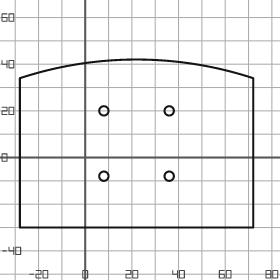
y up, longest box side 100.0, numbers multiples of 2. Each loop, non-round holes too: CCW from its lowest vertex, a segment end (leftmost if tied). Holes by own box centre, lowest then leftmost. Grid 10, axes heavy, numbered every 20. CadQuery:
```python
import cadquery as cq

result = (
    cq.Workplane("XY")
    .moveTo(-28.0, -30.0)
    .lineTo(72.0, -30.0)
    .lineTo(72.0, 34.0)
    .threePointArc((22.0, 42.0), (-28.0, 34.0))
    .close()
    .moveTo(8.0, -8.0)
    .circle(2.0)
    .moveTo(36.0, -8.0)
    .circle(2.0)
    .moveTo(8.0, 20.0)
    .circle(2.0)
    .moveTo(36.0, 20.0)
    .circle(2.0)
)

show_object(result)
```